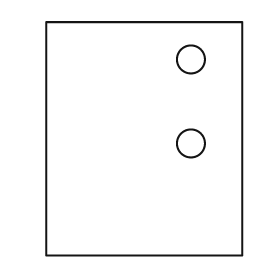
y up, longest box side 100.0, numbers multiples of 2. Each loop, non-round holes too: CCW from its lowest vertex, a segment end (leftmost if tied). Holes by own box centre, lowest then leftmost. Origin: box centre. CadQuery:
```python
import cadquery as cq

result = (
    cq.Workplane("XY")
    .moveTo(-42.0, -50.0)
    .lineTo(42.0, -50.0)
    .lineTo(42.0, 50.0)
    .lineTo(-42.0, 50.0)
    .close()
    .moveTo(20.0, -2.0)
    .circle(6.0)
    .moveTo(20.0, 34.0)
    .circle(6.0)
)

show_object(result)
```